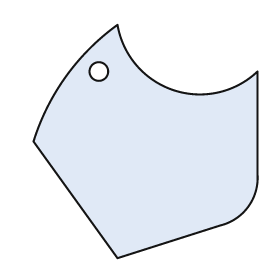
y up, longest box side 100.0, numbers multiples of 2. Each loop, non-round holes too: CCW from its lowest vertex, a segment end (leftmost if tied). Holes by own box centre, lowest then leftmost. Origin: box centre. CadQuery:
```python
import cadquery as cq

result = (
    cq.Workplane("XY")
    .moveTo(-12.0, -50.0)
    .lineTo(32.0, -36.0)
    .threePointArc((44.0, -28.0), (48.0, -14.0))
    .lineTo(48.0, 30.0)
    .threePointArc((12.0, 22.0), (-12.0, 50.0))
    .threePointArc((-34.0, 28.0), (-48.0, 0.0))
    .close()
    .moveTo(-20.0, 30.0)
    .circle(4.0)
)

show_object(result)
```